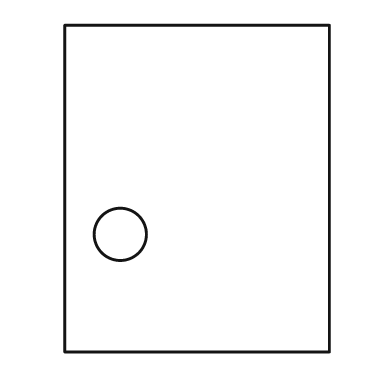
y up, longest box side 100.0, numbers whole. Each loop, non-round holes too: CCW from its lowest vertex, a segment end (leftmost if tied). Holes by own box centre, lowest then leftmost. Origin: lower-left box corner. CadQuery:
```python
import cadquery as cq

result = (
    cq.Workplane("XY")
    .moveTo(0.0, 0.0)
    .lineTo(81.0, 0.0)
    .lineTo(81.0, 100.0)
    .lineTo(0.0, 100.0)
    .close()
    .moveTo(17.0, 36.0)
    .circle(8.0)
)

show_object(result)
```